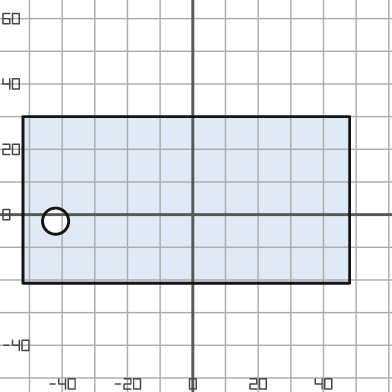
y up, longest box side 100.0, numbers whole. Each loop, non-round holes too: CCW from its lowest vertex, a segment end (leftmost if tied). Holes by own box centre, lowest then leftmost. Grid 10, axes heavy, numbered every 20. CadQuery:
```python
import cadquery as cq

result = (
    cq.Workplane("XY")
    .moveTo(-52.0, -21.0)
    .lineTo(48.0, -21.0)
    .lineTo(48.0, 30.0)
    .lineTo(-52.0, 30.0)
    .close()
    .moveTo(-42.0, -2.0)
    .circle(4.0)
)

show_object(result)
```